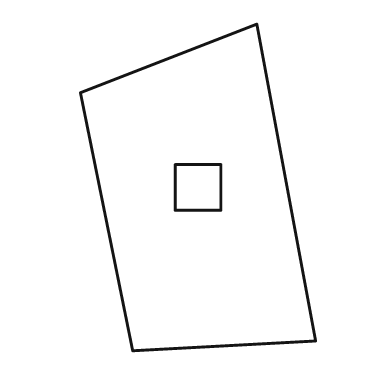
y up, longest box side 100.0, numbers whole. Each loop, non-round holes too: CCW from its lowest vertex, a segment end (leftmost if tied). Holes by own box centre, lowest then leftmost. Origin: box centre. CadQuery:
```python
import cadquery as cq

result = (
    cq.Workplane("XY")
    .moveTo(-20.0, -50.0)
    .lineTo(36.0, -47.0)
    .lineTo(18.0, 50.0)
    .lineTo(-36.0, 29.0)
    .close()
    .moveTo(-7.0, -7.0)
    .lineTo(7.0, -7.0)
    .lineTo(7.0, 7.0)
    .lineTo(-7.0, 7.0)
    .close()
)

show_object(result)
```